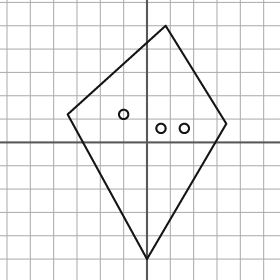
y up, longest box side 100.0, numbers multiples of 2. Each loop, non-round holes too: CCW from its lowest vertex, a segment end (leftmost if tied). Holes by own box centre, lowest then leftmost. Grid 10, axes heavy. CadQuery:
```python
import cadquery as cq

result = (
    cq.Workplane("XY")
    .moveTo(0.0, -50.0)
    .lineTo(34.0, 8.0)
    .lineTo(8.0, 50.0)
    .lineTo(-34.0, 12.0)
    .close()
    .moveTo(6.0, 6.0)
    .circle(2.0)
    .moveTo(16.0, 6.0)
    .circle(2.0)
    .moveTo(-10.0, 12.0)
    .circle(2.0)
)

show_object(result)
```